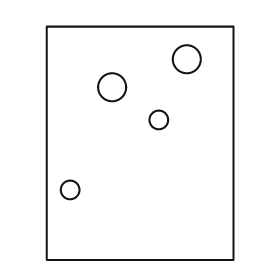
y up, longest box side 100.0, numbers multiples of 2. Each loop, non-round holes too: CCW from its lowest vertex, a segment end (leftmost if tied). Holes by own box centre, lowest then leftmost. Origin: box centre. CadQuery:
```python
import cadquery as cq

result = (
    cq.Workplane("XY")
    .moveTo(-40.0, -50.0)
    .lineTo(40.0, -50.0)
    .lineTo(40.0, 50.0)
    .lineTo(-40.0, 50.0)
    .close()
    .moveTo(-30.0, -20.0)
    .circle(4.0)
    .moveTo(8.0, 10.0)
    .circle(4.0)
    .moveTo(-12.0, 24.0)
    .circle(6.0)
    .moveTo(20.0, 36.0)
    .circle(6.0)
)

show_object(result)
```